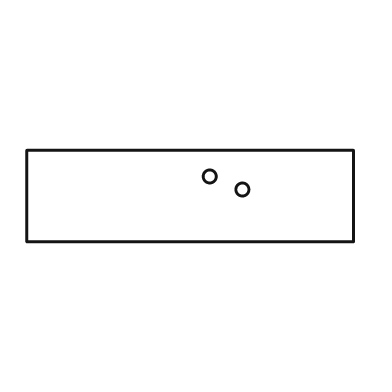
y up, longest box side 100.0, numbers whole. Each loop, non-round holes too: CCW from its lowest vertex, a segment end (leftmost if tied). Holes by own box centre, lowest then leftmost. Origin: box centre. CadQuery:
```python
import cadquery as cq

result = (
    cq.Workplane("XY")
    .moveTo(-50.0, -14.0)
    .lineTo(50.0, -14.0)
    .lineTo(50.0, 14.0)
    .lineTo(-50.0, 14.0)
    .close()
    .moveTo(16.0, 2.0)
    .circle(2.0)
    .moveTo(6.0, 6.0)
    .circle(2.0)
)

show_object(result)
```